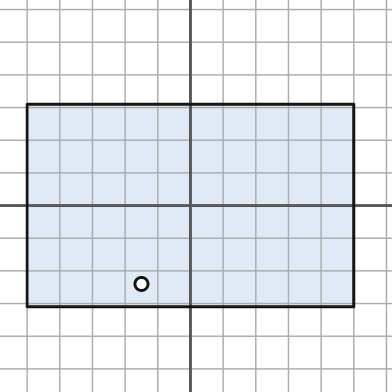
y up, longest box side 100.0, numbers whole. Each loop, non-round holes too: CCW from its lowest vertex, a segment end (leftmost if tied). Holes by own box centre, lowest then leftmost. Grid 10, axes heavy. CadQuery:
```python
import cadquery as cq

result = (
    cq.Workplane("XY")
    .moveTo(-50.0, -31.0)
    .lineTo(50.0, -31.0)
    .lineTo(50.0, 31.0)
    .lineTo(-50.0, 31.0)
    .close()
    .moveTo(-15.0, -24.0)
    .circle(2.0)
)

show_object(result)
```